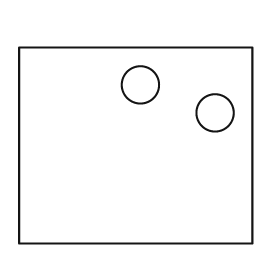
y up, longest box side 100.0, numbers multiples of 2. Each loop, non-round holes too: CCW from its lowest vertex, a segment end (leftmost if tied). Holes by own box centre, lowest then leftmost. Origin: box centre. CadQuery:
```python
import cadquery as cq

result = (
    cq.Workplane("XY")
    .moveTo(-50.0, -42.0)
    .lineTo(50.0, -42.0)
    .lineTo(50.0, 42.0)
    .lineTo(-50.0, 42.0)
    .close()
    .moveTo(34.0, 14.0)
    .circle(8.0)
    .moveTo(2.0, 26.0)
    .circle(8.0)
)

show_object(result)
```